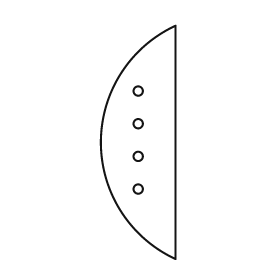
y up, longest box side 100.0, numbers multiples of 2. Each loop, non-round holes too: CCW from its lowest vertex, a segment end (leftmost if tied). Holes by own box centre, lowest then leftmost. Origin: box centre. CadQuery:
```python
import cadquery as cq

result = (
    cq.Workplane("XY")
    .moveTo(16.0, -50.0)
    .lineTo(16.0, 50.0)
    .threePointArc((-16.0, 0.0), (16.0, -50.0))
    .close()
    .moveTo(0.0, -20.0)
    .circle(2.0)
    .moveTo(0.0, -6.0)
    .circle(2.0)
    .moveTo(0.0, 8.0)
    .circle(2.0)
    .moveTo(0.0, 22.0)
    .circle(2.0)
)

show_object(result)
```